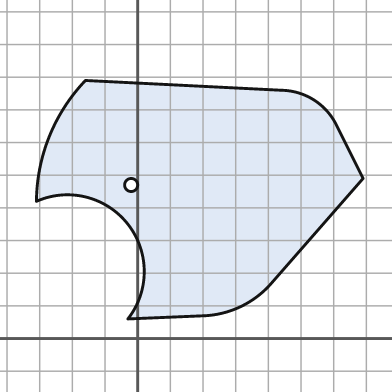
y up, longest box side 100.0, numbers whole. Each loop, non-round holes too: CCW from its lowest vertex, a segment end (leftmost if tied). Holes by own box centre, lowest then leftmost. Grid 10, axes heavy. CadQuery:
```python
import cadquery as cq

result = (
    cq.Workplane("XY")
    .moveTo(-3.0, 6.0)
    .lineTo(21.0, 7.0)
    .threePointArc((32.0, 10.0), (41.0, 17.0))
    .lineTo(69.0, 49.0)
    .lineTo(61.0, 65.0)
    .threePointArc((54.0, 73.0), (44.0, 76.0))
    .lineTo(-16.0, 79.0)
    .threePointArc((-27.0, 62.0), (-31.0, 42.0))
    .threePointArc((-3.0, 35.0), (-3.0, 6.0))
    .close()
    .moveTo(-2.0, 47.0)
    .circle(2.0)
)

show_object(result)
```